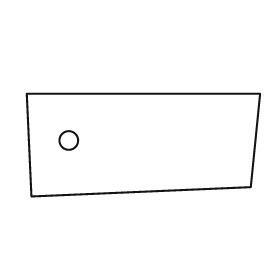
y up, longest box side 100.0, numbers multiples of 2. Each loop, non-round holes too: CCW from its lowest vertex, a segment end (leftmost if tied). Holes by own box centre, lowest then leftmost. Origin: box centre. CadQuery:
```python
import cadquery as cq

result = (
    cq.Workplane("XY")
    .moveTo(-48.0, -22.0)
    .lineTo(46.0, -18.0)
    .lineTo(50.0, 22.0)
    .lineTo(-50.0, 22.0)
    .close()
    .moveTo(-32.0, 2.0)
    .circle(4.0)
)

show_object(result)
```